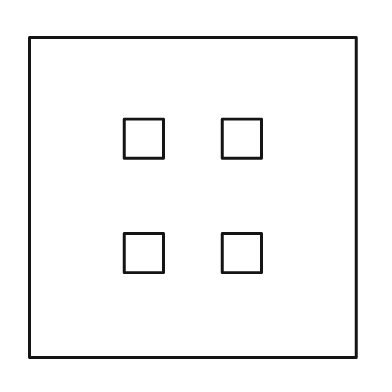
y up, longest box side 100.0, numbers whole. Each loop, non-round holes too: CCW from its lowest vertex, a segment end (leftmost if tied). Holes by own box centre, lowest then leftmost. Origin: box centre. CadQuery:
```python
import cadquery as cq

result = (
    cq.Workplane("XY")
    .moveTo(-50.0, -49.0)
    .lineTo(50.0, -49.0)
    .lineTo(50.0, 49.0)
    .lineTo(-50.0, 49.0)
    .close()
    .moveTo(-21.0, -23.0)
    .lineTo(-9.0, -23.0)
    .lineTo(-9.0, -11.0)
    .lineTo(-21.0, -11.0)
    .close()
    .moveTo(9.0, -23.0)
    .lineTo(21.0, -23.0)
    .lineTo(21.0, -11.0)
    .lineTo(9.0, -11.0)
    .close()
    .moveTo(-21.0, 12.0)
    .lineTo(-9.0, 12.0)
    .lineTo(-9.0, 24.0)
    .lineTo(-21.0, 24.0)
    .close()
    .moveTo(9.0, 12.0)
    .lineTo(21.0, 12.0)
    .lineTo(21.0, 24.0)
    .lineTo(9.0, 24.0)
    .close()
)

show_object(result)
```